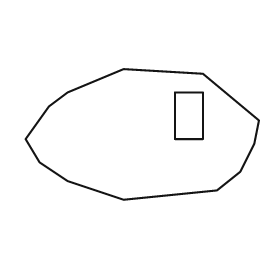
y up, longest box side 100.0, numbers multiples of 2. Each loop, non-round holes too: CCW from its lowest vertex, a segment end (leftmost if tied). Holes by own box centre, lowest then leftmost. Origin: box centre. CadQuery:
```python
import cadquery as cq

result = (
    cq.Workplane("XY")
    .moveTo(-8.0, -28.0)
    .lineTo(32.0, -24.0)
    .lineTo(42.0, -16.0)
    .lineTo(48.0, -4.0)
    .lineTo(50.0, 6.0)
    .lineTo(26.0, 26.0)
    .lineTo(-8.0, 28.0)
    .lineTo(-32.0, 18.0)
    .lineTo(-40.0, 12.0)
    .lineTo(-50.0, -2.0)
    .lineTo(-44.0, -12.0)
    .lineTo(-32.0, -20.0)
    .close()
    .moveTo(14.0, -2.0)
    .lineTo(26.0, -2.0)
    .lineTo(26.0, 18.0)
    .lineTo(14.0, 18.0)
    .close()
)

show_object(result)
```